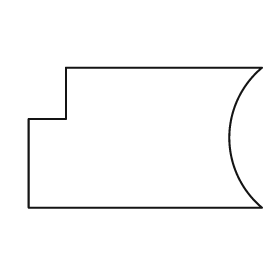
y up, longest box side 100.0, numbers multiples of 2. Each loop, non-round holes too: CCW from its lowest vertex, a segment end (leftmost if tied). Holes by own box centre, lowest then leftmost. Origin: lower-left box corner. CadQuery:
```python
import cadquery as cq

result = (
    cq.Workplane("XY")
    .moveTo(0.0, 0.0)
    .lineTo(100.0, 0.0)
    .threePointArc((86.0, 30.0), (100.0, 60.0))
    .lineTo(16.0, 60.0)
    .lineTo(16.0, 38.0)
    .lineTo(0.0, 38.0)
    .close()
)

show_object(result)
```